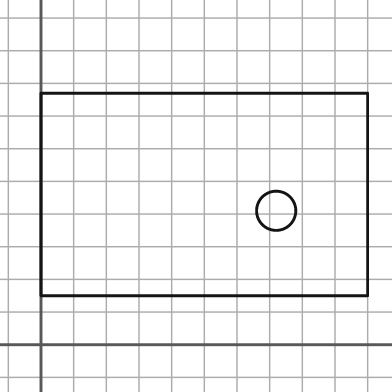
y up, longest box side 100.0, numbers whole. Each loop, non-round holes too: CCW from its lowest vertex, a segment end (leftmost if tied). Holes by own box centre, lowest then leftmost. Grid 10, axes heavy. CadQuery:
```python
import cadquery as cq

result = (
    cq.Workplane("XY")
    .moveTo(0.0, 15.0)
    .lineTo(100.0, 15.0)
    .lineTo(100.0, 77.0)
    .lineTo(0.0, 77.0)
    .close()
    .moveTo(72.0, 41.0)
    .circle(6.0)
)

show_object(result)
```